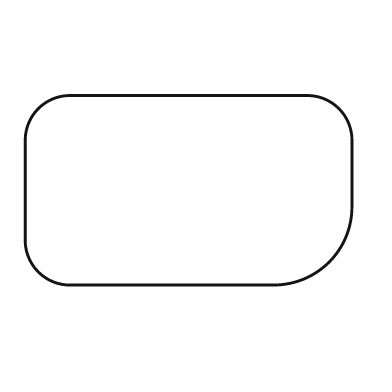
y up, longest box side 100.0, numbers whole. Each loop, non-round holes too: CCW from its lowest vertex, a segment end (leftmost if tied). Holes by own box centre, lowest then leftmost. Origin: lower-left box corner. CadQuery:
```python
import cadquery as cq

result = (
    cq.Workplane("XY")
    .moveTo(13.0, 0.0)
    .lineTo(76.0, 0.0)
    .threePointArc((93.0, 7.0), (100.0, 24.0))
    .lineTo(100.0, 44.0)
    .threePointArc((96.0, 54.0), (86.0, 58.0))
    .lineTo(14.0, 58.0)
    .threePointArc((4.0, 54.0), (0.0, 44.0))
    .lineTo(0.0, 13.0)
    .threePointArc((4.0, 4.0), (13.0, 0.0))
    .close()
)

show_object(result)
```